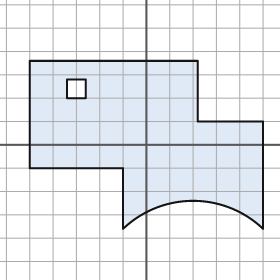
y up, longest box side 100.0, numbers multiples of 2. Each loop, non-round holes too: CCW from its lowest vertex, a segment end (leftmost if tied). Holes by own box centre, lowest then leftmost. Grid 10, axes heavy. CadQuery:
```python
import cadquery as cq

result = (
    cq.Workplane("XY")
    .moveTo(-10.0, -36.0)
    .threePointArc((20.0, -24.0), (50.0, -36.0))
    .lineTo(50.0, 10.0)
    .lineTo(22.0, 10.0)
    .lineTo(22.0, 36.0)
    .lineTo(-50.0, 36.0)
    .lineTo(-50.0, -10.0)
    .lineTo(-10.0, -10.0)
    .close()
    .moveTo(-34.0, 20.0)
    .lineTo(-26.0, 20.0)
    .lineTo(-26.0, 28.0)
    .lineTo(-34.0, 28.0)
    .close()
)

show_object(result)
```